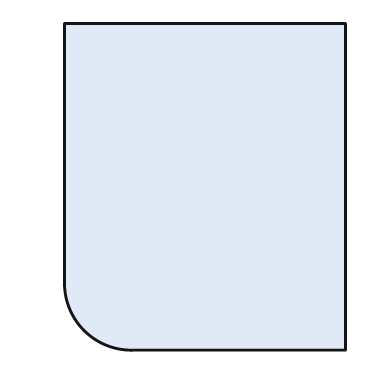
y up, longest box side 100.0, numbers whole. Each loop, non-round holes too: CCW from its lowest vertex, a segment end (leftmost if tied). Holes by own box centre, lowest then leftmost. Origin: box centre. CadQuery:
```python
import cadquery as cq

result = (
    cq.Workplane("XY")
    .moveTo(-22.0, -50.0)
    .lineTo(43.0, -50.0)
    .lineTo(43.0, 50.0)
    .lineTo(-43.0, 50.0)
    .lineTo(-43.0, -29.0)
    .threePointArc((-37.0, -44.0), (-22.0, -50.0))
    .close()
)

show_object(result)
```